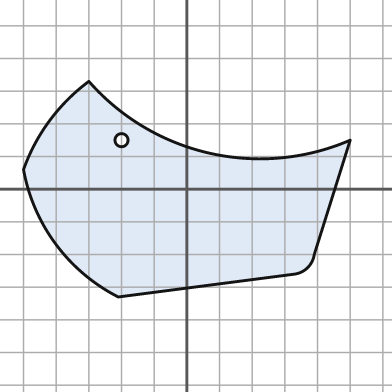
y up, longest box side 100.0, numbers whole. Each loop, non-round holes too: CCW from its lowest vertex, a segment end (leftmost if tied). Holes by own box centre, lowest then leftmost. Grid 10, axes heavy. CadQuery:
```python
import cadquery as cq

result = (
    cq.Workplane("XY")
    .moveTo(-21.0, -33.0)
    .lineTo(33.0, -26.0)
    .threePointArc((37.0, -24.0), (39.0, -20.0))
    .lineTo(50.0, 15.0)
    .threePointArc((7.0, 11.0), (-30.0, 33.0))
    .threePointArc((-42.0, 21.0), (-50.0, 6.0))
    .threePointArc((-40.0, -17.0), (-21.0, -33.0))
    .close()
    .moveTo(-20.0, 15.0)
    .circle(2.0)
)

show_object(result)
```